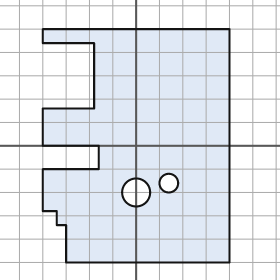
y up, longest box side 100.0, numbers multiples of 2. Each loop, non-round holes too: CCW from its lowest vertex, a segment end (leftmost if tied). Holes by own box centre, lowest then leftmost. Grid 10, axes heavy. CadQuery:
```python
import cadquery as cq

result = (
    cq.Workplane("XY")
    .moveTo(-30.0, -50.0)
    .lineTo(40.0, -50.0)
    .lineTo(40.0, 50.0)
    .lineTo(-40.0, 50.0)
    .lineTo(-40.0, 44.0)
    .lineTo(-18.0, 44.0)
    .lineTo(-18.0, 16.0)
    .lineTo(-40.0, 16.0)
    .lineTo(-40.0, 0.0)
    .lineTo(-16.0, 0.0)
    .lineTo(-16.0, -10.0)
    .lineTo(-40.0, -10.0)
    .lineTo(-40.0, -28.0)
    .lineTo(-34.0, -28.0)
    .lineTo(-34.0, -34.0)
    .lineTo(-30.0, -34.0)
    .close()
    .moveTo(0.0, -20.0)
    .circle(6.0)
    .moveTo(14.0, -16.0)
    .circle(4.0)
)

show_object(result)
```